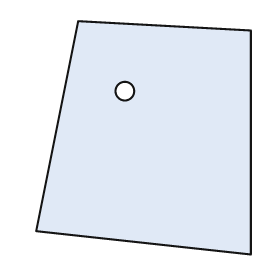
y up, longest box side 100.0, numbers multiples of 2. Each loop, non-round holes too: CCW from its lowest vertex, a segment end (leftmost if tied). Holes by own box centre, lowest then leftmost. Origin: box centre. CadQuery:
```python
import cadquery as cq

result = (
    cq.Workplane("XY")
    .moveTo(46.0, -50.0)
    .lineTo(46.0, 46.0)
    .lineTo(-28.0, 50.0)
    .lineTo(-46.0, -40.0)
    .close()
    .moveTo(-8.0, 20.0)
    .circle(4.0)
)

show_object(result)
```